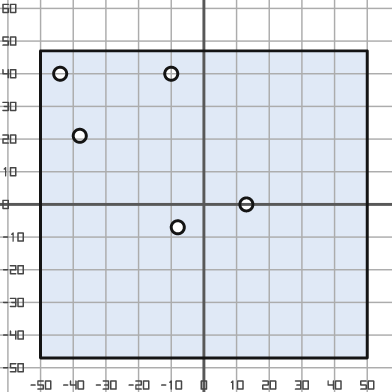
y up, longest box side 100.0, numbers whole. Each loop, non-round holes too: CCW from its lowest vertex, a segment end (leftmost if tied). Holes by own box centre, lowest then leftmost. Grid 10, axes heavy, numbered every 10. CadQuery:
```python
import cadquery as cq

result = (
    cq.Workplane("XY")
    .moveTo(-50.0, -47.0)
    .lineTo(50.0, -47.0)
    .lineTo(50.0, 47.0)
    .lineTo(-50.0, 47.0)
    .close()
    .moveTo(-8.0, -7.0)
    .circle(2.0)
    .moveTo(13.0, 0.0)
    .circle(2.0)
    .moveTo(-38.0, 21.0)
    .circle(2.0)
    .moveTo(-44.0, 40.0)
    .circle(2.0)
    .moveTo(-10.0, 40.0)
    .circle(2.0)
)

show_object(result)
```